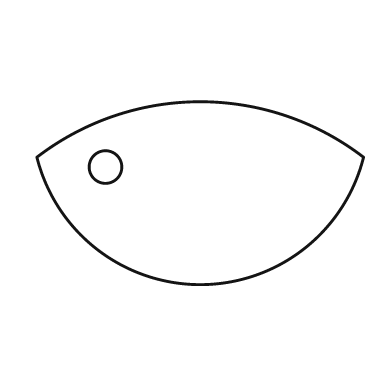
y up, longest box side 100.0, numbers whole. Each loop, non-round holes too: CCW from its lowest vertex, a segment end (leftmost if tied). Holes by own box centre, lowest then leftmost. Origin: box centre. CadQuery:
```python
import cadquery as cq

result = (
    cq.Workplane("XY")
    .moveTo(-50.0, 11.0)
    .threePointArc((0.0, -28.0), (50.0, 11.0))
    .threePointArc((0.0, 28.0), (-50.0, 11.0))
    .close()
    .moveTo(-29.0, 8.0)
    .circle(5.0)
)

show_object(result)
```